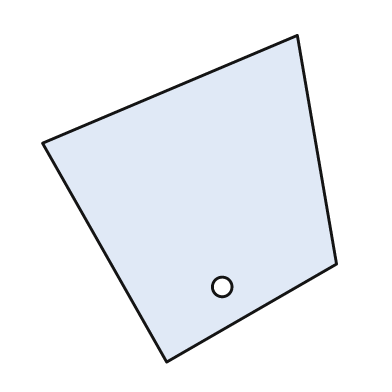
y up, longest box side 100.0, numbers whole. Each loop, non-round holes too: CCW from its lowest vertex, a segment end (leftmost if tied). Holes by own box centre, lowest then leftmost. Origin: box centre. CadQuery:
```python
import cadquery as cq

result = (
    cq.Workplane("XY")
    .moveTo(-7.0, -50.0)
    .lineTo(45.0, -20.0)
    .lineTo(33.0, 50.0)
    .lineTo(-45.0, 17.0)
    .close()
    .moveTo(10.0, -27.0)
    .circle(3.0)
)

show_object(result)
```